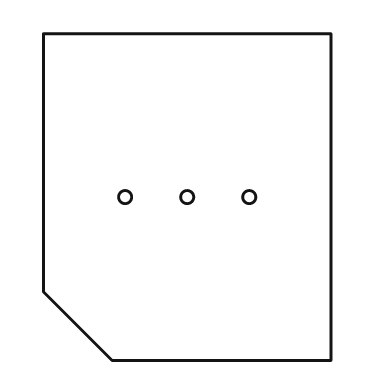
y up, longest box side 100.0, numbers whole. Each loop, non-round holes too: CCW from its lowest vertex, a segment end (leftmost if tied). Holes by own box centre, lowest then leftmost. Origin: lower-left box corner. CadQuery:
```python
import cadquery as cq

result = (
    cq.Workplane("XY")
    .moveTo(21.0, 0.0)
    .lineTo(88.0, 0.0)
    .lineTo(88.0, 100.0)
    .lineTo(0.0, 100.0)
    .lineTo(0.0, 21.0)
    .close()
    .moveTo(25.0, 50.0)
    .circle(2.0)
    .moveTo(44.0, 50.0)
    .circle(2.0)
    .moveTo(63.0, 50.0)
    .circle(2.0)
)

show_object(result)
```